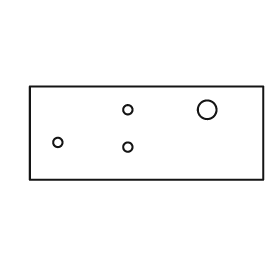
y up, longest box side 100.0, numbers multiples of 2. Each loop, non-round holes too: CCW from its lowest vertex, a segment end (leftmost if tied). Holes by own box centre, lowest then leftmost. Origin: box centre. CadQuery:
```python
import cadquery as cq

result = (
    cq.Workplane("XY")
    .moveTo(-50.0, -20.0)
    .lineTo(50.0, -20.0)
    .lineTo(50.0, 20.0)
    .lineTo(-50.0, 20.0)
    .close()
    .moveTo(-8.0, -6.0)
    .circle(2.0)
    .moveTo(-38.0, -4.0)
    .circle(2.0)
    .moveTo(-8.0, 10.0)
    .circle(2.0)
    .moveTo(26.0, 10.0)
    .circle(4.0)
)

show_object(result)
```